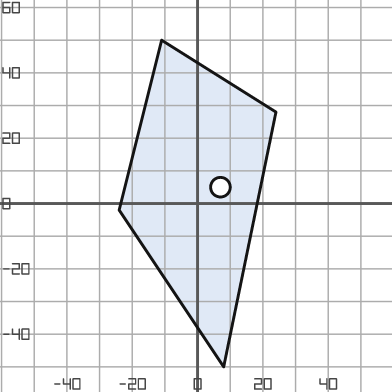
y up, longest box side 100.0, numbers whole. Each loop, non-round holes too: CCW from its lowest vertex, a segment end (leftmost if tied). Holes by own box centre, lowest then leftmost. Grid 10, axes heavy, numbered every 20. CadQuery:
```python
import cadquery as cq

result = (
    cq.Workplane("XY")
    .moveTo(8.0, -50.0)
    .lineTo(24.0, 28.0)
    .lineTo(-11.0, 50.0)
    .lineTo(-24.0, -2.0)
    .close()
    .moveTo(7.0, 5.0)
    .circle(3.0)
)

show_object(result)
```